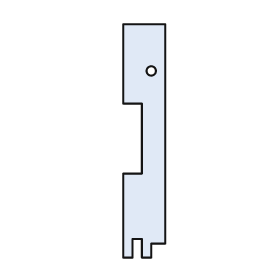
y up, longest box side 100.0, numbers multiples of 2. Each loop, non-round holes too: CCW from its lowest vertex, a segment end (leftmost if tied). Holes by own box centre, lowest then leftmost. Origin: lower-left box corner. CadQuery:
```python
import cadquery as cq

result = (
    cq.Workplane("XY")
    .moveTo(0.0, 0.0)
    .lineTo(4.0, 0.0)
    .lineTo(4.0, 8.0)
    .lineTo(8.0, 8.0)
    .lineTo(8.0, 0.0)
    .lineTo(12.0, 0.0)
    .lineTo(12.0, 6.0)
    .lineTo(18.0, 6.0)
    .lineTo(18.0, 100.0)
    .lineTo(0.0, 100.0)
    .lineTo(0.0, 66.0)
    .lineTo(8.0, 66.0)
    .lineTo(8.0, 36.0)
    .lineTo(0.0, 36.0)
    .close()
    .moveTo(12.0, 80.0)
    .circle(2.0)
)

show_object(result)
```